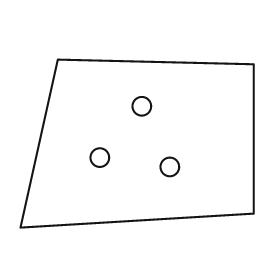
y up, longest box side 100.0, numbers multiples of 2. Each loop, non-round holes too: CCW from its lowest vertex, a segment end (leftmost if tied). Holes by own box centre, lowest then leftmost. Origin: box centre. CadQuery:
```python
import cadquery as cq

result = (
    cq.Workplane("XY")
    .moveTo(-50.0, -36.0)
    .lineTo(50.0, -30.0)
    .lineTo(50.0, 34.0)
    .lineTo(-34.0, 36.0)
    .close()
    .moveTo(14.0, -10.0)
    .circle(4.0)
    .moveTo(-16.0, -6.0)
    .circle(4.0)
    .moveTo(2.0, 16.0)
    .circle(4.0)
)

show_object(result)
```